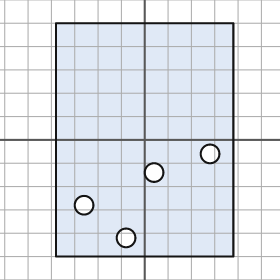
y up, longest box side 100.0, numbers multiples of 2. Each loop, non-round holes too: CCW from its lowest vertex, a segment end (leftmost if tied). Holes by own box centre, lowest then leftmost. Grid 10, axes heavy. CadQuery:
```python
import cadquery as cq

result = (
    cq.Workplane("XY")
    .moveTo(-38.0, -50.0)
    .lineTo(38.0, -50.0)
    .lineTo(38.0, 50.0)
    .lineTo(-38.0, 50.0)
    .close()
    .moveTo(-8.0, -42.0)
    .circle(4.0)
    .moveTo(-26.0, -28.0)
    .circle(4.0)
    .moveTo(4.0, -14.0)
    .circle(4.0)
    .moveTo(28.0, -6.0)
    .circle(4.0)
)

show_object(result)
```